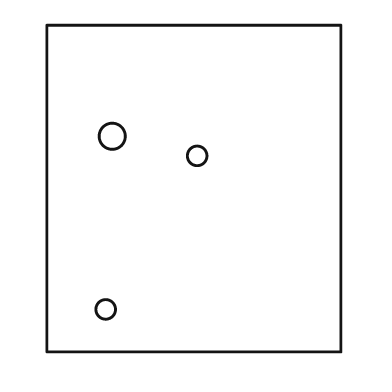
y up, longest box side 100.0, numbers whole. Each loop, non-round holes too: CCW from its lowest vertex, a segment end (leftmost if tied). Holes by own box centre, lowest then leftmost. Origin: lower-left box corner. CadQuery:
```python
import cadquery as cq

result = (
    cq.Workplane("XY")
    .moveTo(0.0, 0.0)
    .lineTo(90.0, 0.0)
    .lineTo(90.0, 100.0)
    .lineTo(0.0, 100.0)
    .close()
    .moveTo(18.0, 13.0)
    .circle(3.0)
    .moveTo(46.0, 60.0)
    .circle(3.0)
    .moveTo(20.0, 66.0)
    .circle(4.0)
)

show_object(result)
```